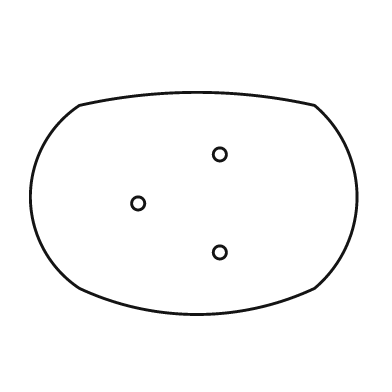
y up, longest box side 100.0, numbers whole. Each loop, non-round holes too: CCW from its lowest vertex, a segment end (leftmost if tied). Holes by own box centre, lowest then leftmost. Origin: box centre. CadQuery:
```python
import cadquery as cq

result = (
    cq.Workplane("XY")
    .moveTo(-35.0, -26.0)
    .threePointArc((1.0, -34.0), (37.0, -26.0))
    .threePointArc((50.0, 2.0), (37.0, 30.0))
    .threePointArc((1.0, 34.0), (-35.0, 30.0))
    .threePointArc((-50.0, 2.0), (-35.0, -26.0))
    .close()
    .moveTo(8.0, -15.0)
    .circle(2.0)
    .moveTo(-17.0, 0.0)
    .circle(2.0)
    .moveTo(8.0, 15.0)
    .circle(2.0)
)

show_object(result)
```